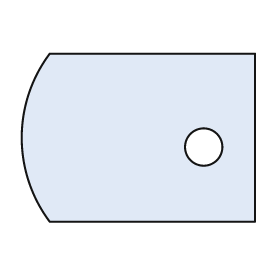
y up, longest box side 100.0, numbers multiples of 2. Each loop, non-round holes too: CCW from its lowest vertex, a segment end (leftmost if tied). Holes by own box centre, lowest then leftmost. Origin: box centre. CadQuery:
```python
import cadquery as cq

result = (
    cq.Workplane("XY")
    .moveTo(-38.0, -36.0)
    .lineTo(50.0, -36.0)
    .lineTo(50.0, 36.0)
    .lineTo(-38.0, 36.0)
    .threePointArc((-50.0, 0.0), (-38.0, -36.0))
    .close()
    .moveTo(28.0, -4.0)
    .circle(8.0)
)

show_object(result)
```